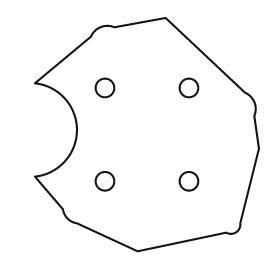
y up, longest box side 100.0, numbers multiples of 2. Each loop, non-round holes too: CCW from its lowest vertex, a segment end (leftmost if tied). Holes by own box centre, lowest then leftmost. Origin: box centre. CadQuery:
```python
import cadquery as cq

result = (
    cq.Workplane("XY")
    .moveTo(-4.0, -50.0)
    .lineTo(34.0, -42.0)
    .threePointArc((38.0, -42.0), (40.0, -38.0))
    .lineTo(48.0, -6.0)
    .lineTo(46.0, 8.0)
    .threePointArc((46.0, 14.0), (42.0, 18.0))
    .lineTo(8.0, 50.0)
    .lineTo(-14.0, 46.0)
    .threePointArc((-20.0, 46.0), (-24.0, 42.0))
    .lineTo(-48.0, 22.0)
    .threePointArc((-30.0, 2.0), (-48.0, -18.0))
    .lineTo(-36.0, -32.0)
    .threePointArc((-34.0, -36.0), (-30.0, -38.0))
    .close()
    .moveTo(-18.0, -20.0)
    .circle(4.0)
    .moveTo(18.0, -20.0)
    .circle(4.0)
    .moveTo(-18.0, 20.0)
    .circle(4.0)
    .moveTo(18.0, 20.0)
    .circle(4.0)
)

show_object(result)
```